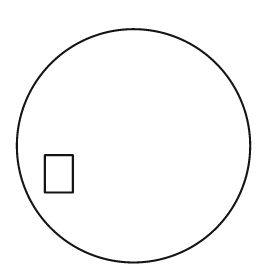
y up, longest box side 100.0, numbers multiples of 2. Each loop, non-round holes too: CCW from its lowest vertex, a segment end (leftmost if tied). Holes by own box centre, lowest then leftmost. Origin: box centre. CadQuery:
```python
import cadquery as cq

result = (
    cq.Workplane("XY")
    .moveTo(0.0, 0.0)
    .circle(50.0)
    .moveTo(-38.0, -20.0)
    .lineTo(-26.0, -20.0)
    .lineTo(-26.0, -4.0)
    .lineTo(-38.0, -4.0)
    .close()
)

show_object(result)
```